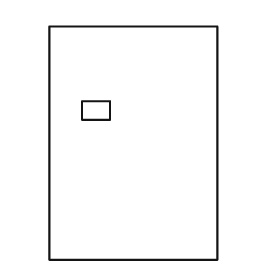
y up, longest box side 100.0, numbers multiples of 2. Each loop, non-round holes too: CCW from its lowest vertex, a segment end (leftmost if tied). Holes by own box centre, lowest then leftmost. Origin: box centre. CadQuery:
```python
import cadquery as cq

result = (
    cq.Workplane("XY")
    .moveTo(-36.0, -50.0)
    .lineTo(36.0, -50.0)
    .lineTo(36.0, 50.0)
    .lineTo(-36.0, 50.0)
    .close()
    .moveTo(-22.0, 10.0)
    .lineTo(-10.0, 10.0)
    .lineTo(-10.0, 18.0)
    .lineTo(-22.0, 18.0)
    .close()
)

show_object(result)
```